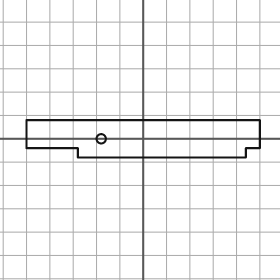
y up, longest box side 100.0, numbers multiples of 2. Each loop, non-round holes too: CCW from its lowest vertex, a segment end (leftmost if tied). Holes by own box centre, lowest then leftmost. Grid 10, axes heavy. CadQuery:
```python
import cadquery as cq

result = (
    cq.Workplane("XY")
    .moveTo(-28.0, -8.0)
    .lineTo(44.0, -8.0)
    .lineTo(44.0, -4.0)
    .lineTo(50.0, -4.0)
    .lineTo(50.0, 8.0)
    .lineTo(-50.0, 8.0)
    .lineTo(-50.0, -4.0)
    .lineTo(-28.0, -4.0)
    .close()
    .moveTo(-18.0, 0.0)
    .circle(2.0)
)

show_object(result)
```